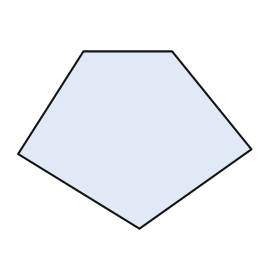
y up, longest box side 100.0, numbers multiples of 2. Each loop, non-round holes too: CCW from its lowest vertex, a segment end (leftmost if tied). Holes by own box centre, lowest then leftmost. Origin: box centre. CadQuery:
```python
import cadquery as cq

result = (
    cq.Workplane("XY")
    .moveTo(2.0, -38.0)
    .lineTo(50.0, -4.0)
    .lineTo(16.0, 38.0)
    .lineTo(-22.0, 38.0)
    .lineTo(-50.0, -6.0)
    .close()
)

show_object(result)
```